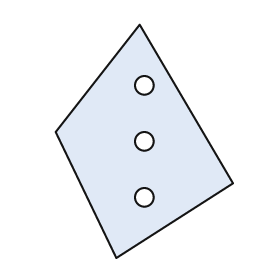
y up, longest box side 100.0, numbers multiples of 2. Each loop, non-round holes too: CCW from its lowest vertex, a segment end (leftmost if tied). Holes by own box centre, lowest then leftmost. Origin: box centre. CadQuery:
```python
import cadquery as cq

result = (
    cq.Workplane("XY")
    .moveTo(-12.0, -50.0)
    .lineTo(38.0, -18.0)
    .lineTo(-2.0, 50.0)
    .lineTo(-38.0, 4.0)
    .close()
    .moveTo(0.0, -24.0)
    .circle(4.0)
    .moveTo(0.0, 0.0)
    .circle(4.0)
    .moveTo(0.0, 24.0)
    .circle(4.0)
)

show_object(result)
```